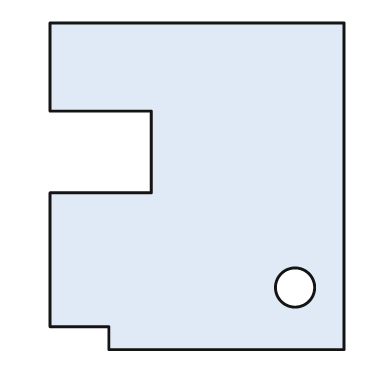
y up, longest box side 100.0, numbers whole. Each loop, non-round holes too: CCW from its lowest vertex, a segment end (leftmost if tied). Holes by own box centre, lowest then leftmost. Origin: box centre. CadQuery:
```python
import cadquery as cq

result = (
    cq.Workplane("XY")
    .moveTo(-27.0, -50.0)
    .lineTo(45.0, -50.0)
    .lineTo(45.0, 50.0)
    .lineTo(-45.0, 50.0)
    .lineTo(-45.0, 23.0)
    .lineTo(-14.0, 23.0)
    .lineTo(-14.0, -2.0)
    .lineTo(-45.0, -2.0)
    .lineTo(-45.0, -43.0)
    .lineTo(-27.0, -43.0)
    .close()
    .moveTo(30.0, -31.0)
    .circle(6.0)
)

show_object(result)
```